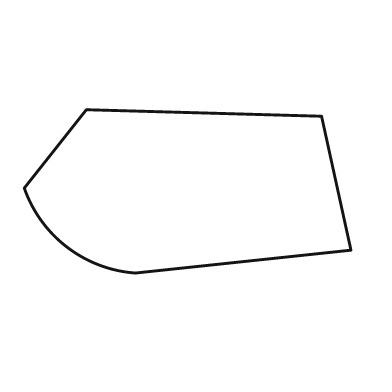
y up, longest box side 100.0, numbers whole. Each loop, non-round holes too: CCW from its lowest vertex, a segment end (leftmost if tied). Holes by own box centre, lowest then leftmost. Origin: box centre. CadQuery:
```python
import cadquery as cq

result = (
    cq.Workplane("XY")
    .moveTo(-16.0, -25.0)
    .lineTo(50.0, -18.0)
    .lineTo(41.0, 23.0)
    .lineTo(-31.0, 25.0)
    .lineTo(-50.0, 1.0)
    .threePointArc((-37.0, -17.0), (-16.0, -25.0))
    .close()
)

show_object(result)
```